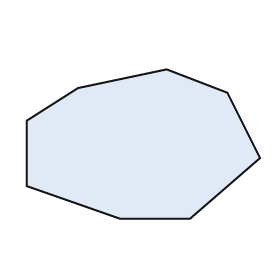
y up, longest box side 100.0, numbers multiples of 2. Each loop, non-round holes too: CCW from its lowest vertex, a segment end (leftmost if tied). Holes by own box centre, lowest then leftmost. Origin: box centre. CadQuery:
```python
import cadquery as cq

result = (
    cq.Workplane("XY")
    .moveTo(-10.0, -32.0)
    .lineTo(20.0, -32.0)
    .lineTo(50.0, -6.0)
    .lineTo(36.0, 22.0)
    .lineTo(10.0, 32.0)
    .lineTo(-28.0, 24.0)
    .lineTo(-50.0, 10.0)
    .lineTo(-50.0, -18.0)
    .close()
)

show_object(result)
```